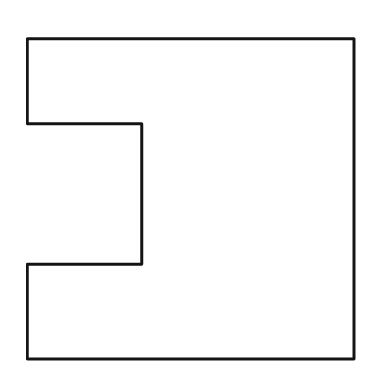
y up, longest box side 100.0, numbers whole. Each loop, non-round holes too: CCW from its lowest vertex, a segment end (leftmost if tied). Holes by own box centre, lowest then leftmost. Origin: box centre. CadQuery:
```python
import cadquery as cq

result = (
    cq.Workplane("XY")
    .moveTo(-50.0, -49.0)
    .lineTo(50.0, -49.0)
    .lineTo(50.0, 49.0)
    .lineTo(-50.0, 49.0)
    .lineTo(-50.0, 23.0)
    .lineTo(-15.0, 23.0)
    .lineTo(-15.0, -20.0)
    .lineTo(-50.0, -20.0)
    .close()
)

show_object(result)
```